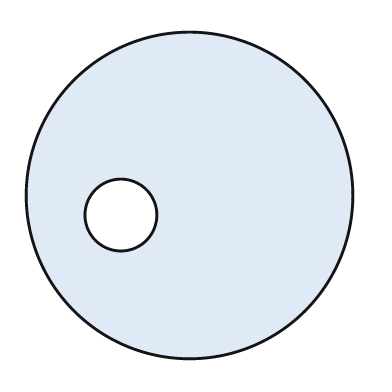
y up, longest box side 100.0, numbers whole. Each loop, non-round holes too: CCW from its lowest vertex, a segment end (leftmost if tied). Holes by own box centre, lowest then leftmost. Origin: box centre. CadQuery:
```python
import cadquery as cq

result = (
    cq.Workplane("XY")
    .moveTo(0.0, 0.0)
    .circle(50.0)
    .moveTo(-21.0, -6.0)
    .circle(11.0)
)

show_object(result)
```